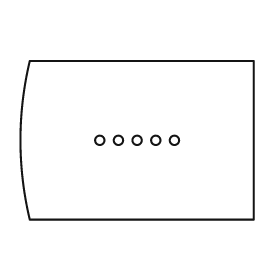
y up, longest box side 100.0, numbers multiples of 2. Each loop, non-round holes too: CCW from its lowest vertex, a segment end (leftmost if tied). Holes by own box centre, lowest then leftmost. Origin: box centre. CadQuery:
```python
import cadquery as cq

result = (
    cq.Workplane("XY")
    .moveTo(-46.0, -34.0)
    .lineTo(50.0, -34.0)
    .lineTo(50.0, 34.0)
    .lineTo(-46.0, 34.0)
    .threePointArc((-50.0, 0.0), (-46.0, -34.0))
    .close()
    .moveTo(-16.0, 0.0)
    .circle(2.0)
    .moveTo(-8.0, 0.0)
    .circle(2.0)
    .moveTo(0.0, 0.0)
    .circle(2.0)
    .moveTo(8.0, 0.0)
    .circle(2.0)
    .moveTo(16.0, 0.0)
    .circle(2.0)
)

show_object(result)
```